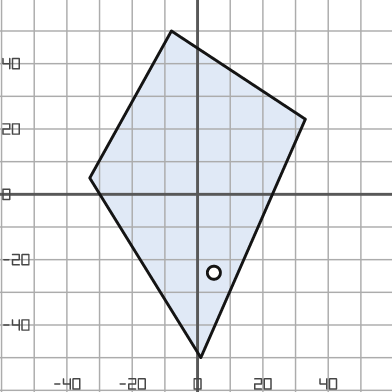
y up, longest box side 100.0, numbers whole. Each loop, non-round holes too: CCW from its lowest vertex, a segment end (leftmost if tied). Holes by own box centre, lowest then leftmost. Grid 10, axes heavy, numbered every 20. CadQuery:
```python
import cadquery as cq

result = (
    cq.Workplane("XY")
    .moveTo(1.0, -50.0)
    .lineTo(33.0, 23.0)
    .lineTo(-8.0, 50.0)
    .lineTo(-33.0, 5.0)
    .close()
    .moveTo(5.0, -24.0)
    .circle(2.0)
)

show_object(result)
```